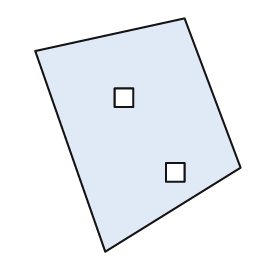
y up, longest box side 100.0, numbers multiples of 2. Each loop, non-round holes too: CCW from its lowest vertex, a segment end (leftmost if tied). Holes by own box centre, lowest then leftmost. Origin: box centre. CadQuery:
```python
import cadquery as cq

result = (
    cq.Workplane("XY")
    .moveTo(-14.0, -50.0)
    .lineTo(44.0, -14.0)
    .lineTo(20.0, 50.0)
    .lineTo(-44.0, 36.0)
    .close()
    .moveTo(12.0, -20.0)
    .lineTo(20.0, -20.0)
    .lineTo(20.0, -12.0)
    .lineTo(12.0, -12.0)
    .close()
    .moveTo(-10.0, 12.0)
    .lineTo(-2.0, 12.0)
    .lineTo(-2.0, 20.0)
    .lineTo(-10.0, 20.0)
    .close()
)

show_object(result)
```